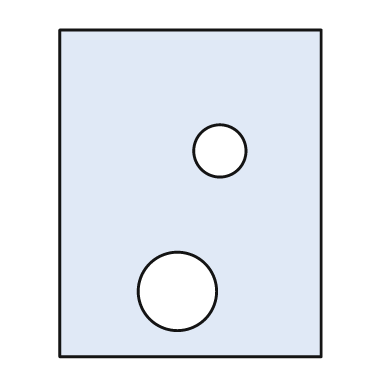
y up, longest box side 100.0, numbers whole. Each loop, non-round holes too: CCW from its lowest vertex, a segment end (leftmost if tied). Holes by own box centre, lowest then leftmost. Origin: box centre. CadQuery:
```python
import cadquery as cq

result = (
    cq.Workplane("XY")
    .moveTo(-40.0, -50.0)
    .lineTo(40.0, -50.0)
    .lineTo(40.0, 50.0)
    .lineTo(-40.0, 50.0)
    .close()
    .moveTo(-4.0, -30.0)
    .circle(12.0)
    .moveTo(9.0, 13.0)
    .circle(8.0)
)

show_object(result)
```